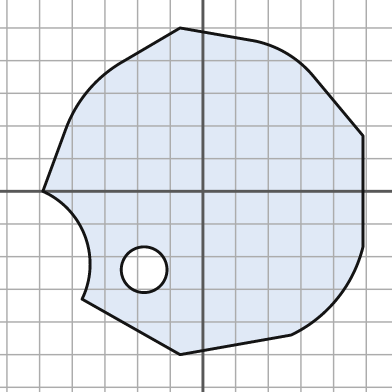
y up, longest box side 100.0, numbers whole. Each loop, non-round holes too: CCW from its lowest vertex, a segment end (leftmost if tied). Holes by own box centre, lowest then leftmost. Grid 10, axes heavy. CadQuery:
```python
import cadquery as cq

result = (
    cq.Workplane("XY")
    .moveTo(-7.0, -50.0)
    .lineTo(27.0, -44.0)
    .threePointArc((41.0, -33.0), (49.0, -17.0))
    .lineTo(49.0, 17.0)
    .lineTo(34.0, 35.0)
    .threePointArc((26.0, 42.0), (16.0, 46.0))
    .lineTo(-7.0, 50.0)
    .lineTo(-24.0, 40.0)
    .threePointArc((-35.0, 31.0), (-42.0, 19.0))
    .lineTo(-49.0, 0.0)
    .threePointArc((-36.0, -14.0), (-37.0, -33.0))
    .close()
    .moveTo(-18.0, -24.0)
    .circle(7.0)
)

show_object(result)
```